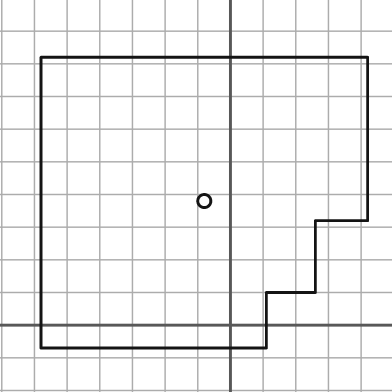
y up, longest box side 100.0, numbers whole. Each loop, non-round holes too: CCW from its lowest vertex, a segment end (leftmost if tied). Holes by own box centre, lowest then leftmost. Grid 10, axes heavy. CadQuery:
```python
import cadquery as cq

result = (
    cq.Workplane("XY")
    .moveTo(-58.0, -7.0)
    .lineTo(11.0, -7.0)
    .lineTo(11.0, 10.0)
    .lineTo(26.0, 10.0)
    .lineTo(26.0, 32.0)
    .lineTo(42.0, 32.0)
    .lineTo(42.0, 82.0)
    .lineTo(-58.0, 82.0)
    .close()
    .moveTo(-8.0, 38.0)
    .circle(2.0)
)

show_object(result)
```